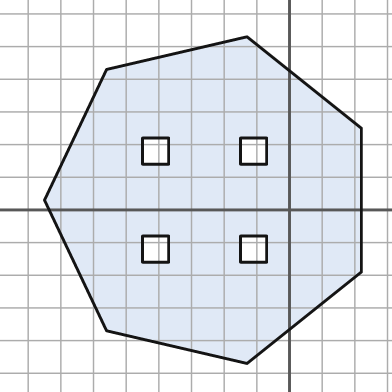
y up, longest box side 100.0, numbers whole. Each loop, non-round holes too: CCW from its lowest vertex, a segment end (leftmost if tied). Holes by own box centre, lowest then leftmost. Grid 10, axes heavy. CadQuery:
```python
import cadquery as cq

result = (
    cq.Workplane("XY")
    .moveTo(-13.0, -47.0)
    .lineTo(22.0, -19.0)
    .lineTo(22.0, 25.0)
    .lineTo(-13.0, 53.0)
    .lineTo(-56.0, 43.0)
    .lineTo(-75.0, 3.0)
    .lineTo(-56.0, -37.0)
    .close()
    .moveTo(-45.0, -16.0)
    .lineTo(-37.0, -16.0)
    .lineTo(-37.0, -8.0)
    .lineTo(-45.0, -8.0)
    .close()
    .moveTo(-15.0, -16.0)
    .lineTo(-7.0, -16.0)
    .lineTo(-7.0, -8.0)
    .lineTo(-15.0, -8.0)
    .close()
    .moveTo(-45.0, 14.0)
    .lineTo(-37.0, 14.0)
    .lineTo(-37.0, 22.0)
    .lineTo(-45.0, 22.0)
    .close()
    .moveTo(-15.0, 14.0)
    .lineTo(-7.0, 14.0)
    .lineTo(-7.0, 22.0)
    .lineTo(-15.0, 22.0)
    .close()
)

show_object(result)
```